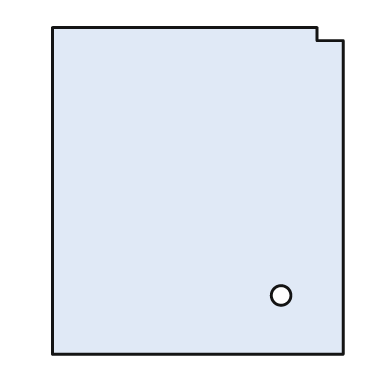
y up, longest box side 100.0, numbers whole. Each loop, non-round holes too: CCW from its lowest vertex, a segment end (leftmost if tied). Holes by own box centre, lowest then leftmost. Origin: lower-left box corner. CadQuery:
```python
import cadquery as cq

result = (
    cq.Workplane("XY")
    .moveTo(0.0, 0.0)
    .lineTo(89.0, 0.0)
    .lineTo(89.0, 96.0)
    .lineTo(81.0, 96.0)
    .lineTo(81.0, 100.0)
    .lineTo(0.0, 100.0)
    .close()
    .moveTo(70.0, 18.0)
    .circle(3.0)
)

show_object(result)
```